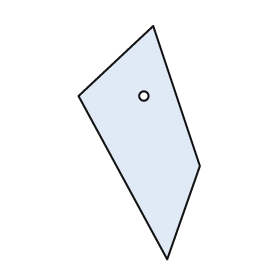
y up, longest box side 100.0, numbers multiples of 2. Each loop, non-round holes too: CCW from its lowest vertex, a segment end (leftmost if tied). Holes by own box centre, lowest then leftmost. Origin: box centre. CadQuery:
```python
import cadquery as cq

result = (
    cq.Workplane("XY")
    .moveTo(12.0, -50.0)
    .lineTo(26.0, -10.0)
    .lineTo(6.0, 50.0)
    .lineTo(-26.0, 20.0)
    .close()
    .moveTo(2.0, 20.0)
    .circle(2.0)
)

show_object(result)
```